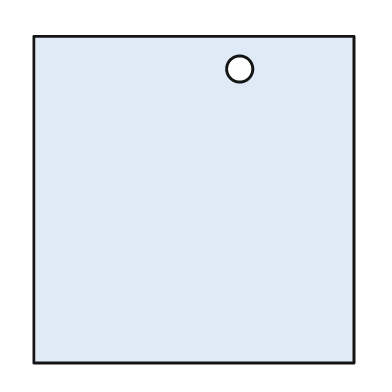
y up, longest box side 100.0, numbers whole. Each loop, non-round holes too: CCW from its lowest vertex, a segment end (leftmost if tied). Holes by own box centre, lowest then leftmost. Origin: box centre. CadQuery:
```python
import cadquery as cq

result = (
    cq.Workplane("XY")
    .moveTo(-49.0, -50.0)
    .lineTo(49.0, -50.0)
    .lineTo(49.0, 50.0)
    .lineTo(-49.0, 50.0)
    .close()
    .moveTo(14.0, 40.0)
    .circle(4.0)
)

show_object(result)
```